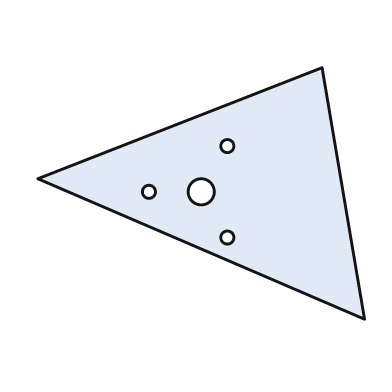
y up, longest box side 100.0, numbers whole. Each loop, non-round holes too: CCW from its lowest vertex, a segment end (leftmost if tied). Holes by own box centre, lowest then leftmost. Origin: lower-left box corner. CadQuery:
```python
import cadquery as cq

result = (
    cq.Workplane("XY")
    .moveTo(100.0, 0.0)
    .lineTo(87.0, 77.0)
    .lineTo(0.0, 43.0)
    .close()
    .moveTo(58.0, 25.0)
    .circle(2.0)
    .moveTo(34.0, 39.0)
    .circle(2.0)
    .moveTo(50.0, 39.0)
    .circle(4.0)
    .moveTo(58.0, 53.0)
    .circle(2.0)
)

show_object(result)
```